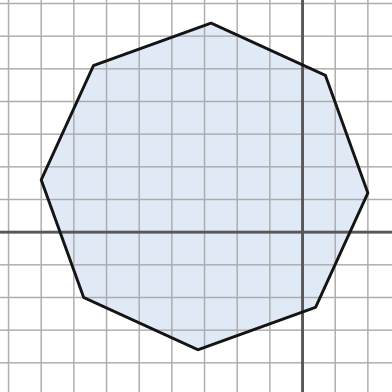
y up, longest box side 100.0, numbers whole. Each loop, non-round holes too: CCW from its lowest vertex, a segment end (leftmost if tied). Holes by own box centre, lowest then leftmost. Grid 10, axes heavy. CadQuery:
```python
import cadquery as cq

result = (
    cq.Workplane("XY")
    .moveTo(-32.0, -36.0)
    .lineTo(4.0, -23.0)
    .lineTo(20.0, 12.0)
    .lineTo(7.0, 48.0)
    .lineTo(-28.0, 64.0)
    .lineTo(-64.0, 51.0)
    .lineTo(-80.0, 16.0)
    .lineTo(-67.0, -20.0)
    .close()
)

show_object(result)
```